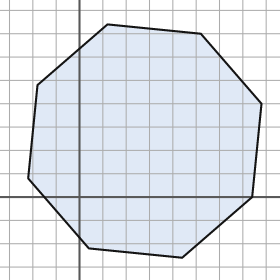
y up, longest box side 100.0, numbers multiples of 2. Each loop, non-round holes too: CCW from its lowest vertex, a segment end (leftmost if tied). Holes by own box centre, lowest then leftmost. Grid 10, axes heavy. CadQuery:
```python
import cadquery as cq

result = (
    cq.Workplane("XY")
    .moveTo(44.0, -26.0)
    .lineTo(74.0, 0.0)
    .lineTo(78.0, 40.0)
    .lineTo(52.0, 70.0)
    .lineTo(12.0, 74.0)
    .lineTo(-18.0, 48.0)
    .lineTo(-22.0, 8.0)
    .lineTo(4.0, -22.0)
    .close()
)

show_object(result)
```